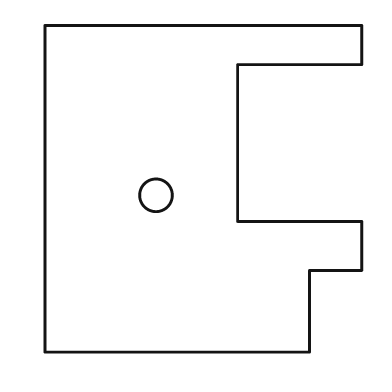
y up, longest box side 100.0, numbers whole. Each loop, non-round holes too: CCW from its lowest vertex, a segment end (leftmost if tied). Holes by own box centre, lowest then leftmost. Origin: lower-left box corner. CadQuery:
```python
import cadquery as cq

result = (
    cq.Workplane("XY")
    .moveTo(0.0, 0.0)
    .lineTo(81.0, 0.0)
    .lineTo(81.0, 25.0)
    .lineTo(97.0, 25.0)
    .lineTo(97.0, 40.0)
    .lineTo(59.0, 40.0)
    .lineTo(59.0, 88.0)
    .lineTo(97.0, 88.0)
    .lineTo(97.0, 100.0)
    .lineTo(0.0, 100.0)
    .close()
    .moveTo(34.0, 48.0)
    .circle(5.0)
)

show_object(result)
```